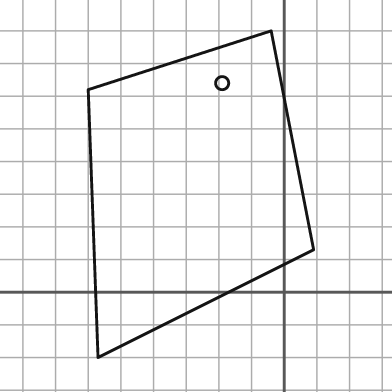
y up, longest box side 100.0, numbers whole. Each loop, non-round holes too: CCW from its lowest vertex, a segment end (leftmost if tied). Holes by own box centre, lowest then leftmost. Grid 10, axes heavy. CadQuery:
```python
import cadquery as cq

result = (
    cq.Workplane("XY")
    .moveTo(-57.0, -20.0)
    .lineTo(9.0, 13.0)
    .lineTo(-4.0, 80.0)
    .lineTo(-60.0, 62.0)
    .close()
    .moveTo(-19.0, 64.0)
    .circle(2.0)
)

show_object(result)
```